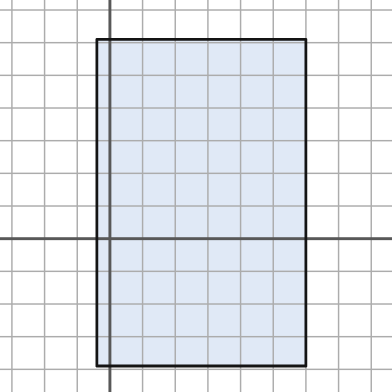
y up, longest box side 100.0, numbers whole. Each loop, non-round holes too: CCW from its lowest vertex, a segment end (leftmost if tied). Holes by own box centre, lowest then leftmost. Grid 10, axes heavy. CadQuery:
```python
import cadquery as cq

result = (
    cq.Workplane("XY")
    .moveTo(-4.0, -39.0)
    .lineTo(60.0, -39.0)
    .lineTo(60.0, 61.0)
    .lineTo(-4.0, 61.0)
    .close()
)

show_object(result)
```